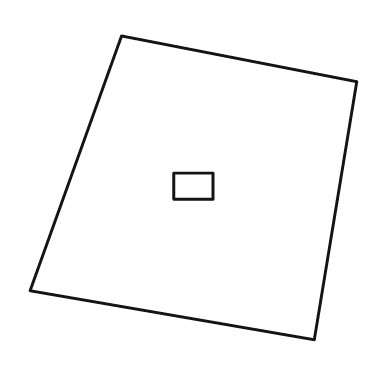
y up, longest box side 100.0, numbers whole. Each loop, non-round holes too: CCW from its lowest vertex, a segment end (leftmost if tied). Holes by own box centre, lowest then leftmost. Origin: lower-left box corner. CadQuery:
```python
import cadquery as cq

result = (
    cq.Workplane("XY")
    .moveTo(87.0, 0.0)
    .lineTo(100.0, 79.0)
    .lineTo(28.0, 93.0)
    .lineTo(0.0, 15.0)
    .close()
    .moveTo(44.0, 43.0)
    .lineTo(56.0, 43.0)
    .lineTo(56.0, 51.0)
    .lineTo(44.0, 51.0)
    .close()
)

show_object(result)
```